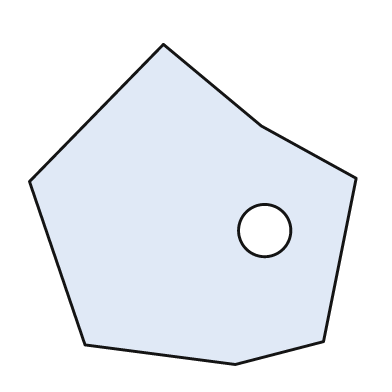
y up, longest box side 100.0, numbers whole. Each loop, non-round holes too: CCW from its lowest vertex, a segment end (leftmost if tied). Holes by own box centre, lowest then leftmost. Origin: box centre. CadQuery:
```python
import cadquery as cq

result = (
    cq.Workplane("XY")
    .moveTo(13.0, -49.0)
    .lineTo(40.0, -42.0)
    .lineTo(50.0, 8.0)
    .lineTo(21.0, 24.0)
    .lineTo(-9.0, 49.0)
    .lineTo(-50.0, 7.0)
    .lineTo(-33.0, -43.0)
    .close()
    .moveTo(22.0, -8.0)
    .circle(8.0)
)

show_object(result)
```